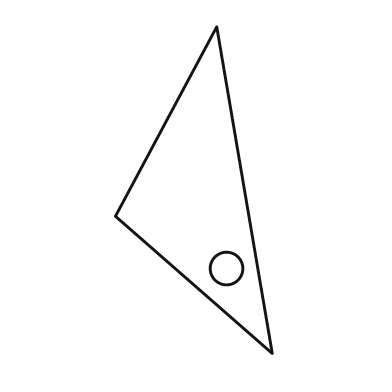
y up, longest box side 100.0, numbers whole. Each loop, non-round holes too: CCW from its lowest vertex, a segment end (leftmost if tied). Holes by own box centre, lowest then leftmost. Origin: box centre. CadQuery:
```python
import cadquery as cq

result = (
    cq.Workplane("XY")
    .moveTo(24.0, -50.0)
    .lineTo(7.0, 50.0)
    .lineTo(-24.0, -8.0)
    .close()
    .moveTo(10.0, -24.0)
    .circle(5.0)
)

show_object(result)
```